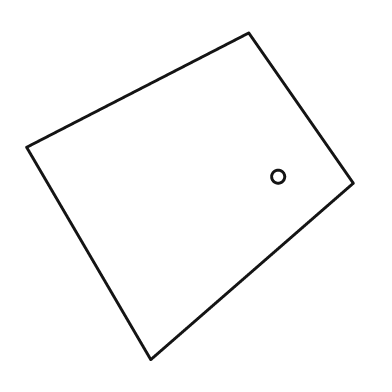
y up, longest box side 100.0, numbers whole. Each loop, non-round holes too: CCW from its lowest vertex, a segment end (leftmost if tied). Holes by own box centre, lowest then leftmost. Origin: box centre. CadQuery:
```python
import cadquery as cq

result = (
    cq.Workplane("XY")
    .moveTo(-12.0, -50.0)
    .lineTo(50.0, 4.0)
    .lineTo(18.0, 50.0)
    .lineTo(-50.0, 15.0)
    .close()
    .moveTo(27.0, 6.0)
    .circle(2.0)
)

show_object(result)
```